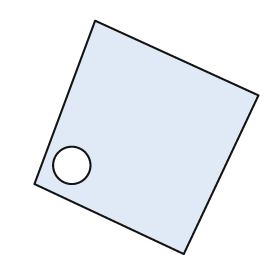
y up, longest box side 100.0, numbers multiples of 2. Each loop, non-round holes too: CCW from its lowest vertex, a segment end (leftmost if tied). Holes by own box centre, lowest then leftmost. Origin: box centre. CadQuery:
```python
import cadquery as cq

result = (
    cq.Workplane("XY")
    .moveTo(16.0, -50.0)
    .lineTo(48.0, 18.0)
    .lineTo(-22.0, 50.0)
    .lineTo(-48.0, -20.0)
    .close()
    .moveTo(-32.0, -12.0)
    .circle(8.0)
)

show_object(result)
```